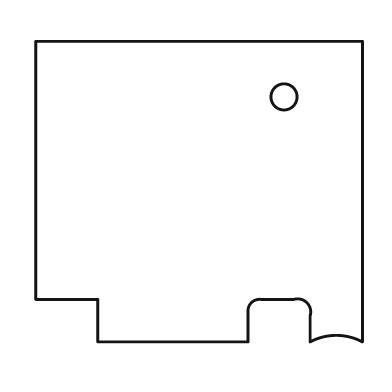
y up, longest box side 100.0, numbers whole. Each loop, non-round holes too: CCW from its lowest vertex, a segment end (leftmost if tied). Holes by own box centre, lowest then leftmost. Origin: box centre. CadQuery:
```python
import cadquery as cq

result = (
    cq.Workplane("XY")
    .moveTo(-31.0, -46.0)
    .lineTo(15.0, -46.0)
    .lineTo(15.0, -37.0)
    .threePointArc((16.0, -34.0), (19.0, -33.0))
    .lineTo(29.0, -33.0)
    .threePointArc((33.0, -34.0), (34.0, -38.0))
    .lineTo(34.0, -46.0)
    .threePointArc((42.0, -44.0), (50.0, -46.0))
    .lineTo(50.0, 46.0)
    .lineTo(-50.0, 46.0)
    .lineTo(-50.0, -33.0)
    .lineTo(-31.0, -33.0)
    .close()
    .moveTo(26.0, 29.0)
    .circle(4.0)
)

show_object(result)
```